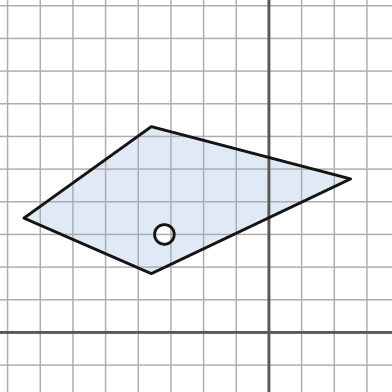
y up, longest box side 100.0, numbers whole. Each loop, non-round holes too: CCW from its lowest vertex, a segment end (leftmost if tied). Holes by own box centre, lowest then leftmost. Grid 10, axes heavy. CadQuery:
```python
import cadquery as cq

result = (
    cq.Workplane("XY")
    .moveTo(-36.0, 18.0)
    .lineTo(25.0, 47.0)
    .lineTo(-36.0, 63.0)
    .lineTo(-75.0, 35.0)
    .close()
    .moveTo(-32.0, 30.0)
    .circle(3.0)
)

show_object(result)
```